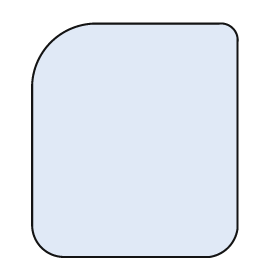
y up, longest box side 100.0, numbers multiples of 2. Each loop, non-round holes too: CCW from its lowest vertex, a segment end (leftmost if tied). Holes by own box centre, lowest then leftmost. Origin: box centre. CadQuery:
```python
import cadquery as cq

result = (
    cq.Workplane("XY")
    .moveTo(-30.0, -50.0)
    .lineTo(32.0, -50.0)
    .threePointArc((40.0, -46.0), (44.0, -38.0))
    .lineTo(44.0, 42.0)
    .threePointArc((42.0, 48.0), (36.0, 50.0))
    .lineTo(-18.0, 50.0)
    .threePointArc((-36.0, 42.0), (-44.0, 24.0))
    .lineTo(-44.0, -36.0)
    .threePointArc((-40.0, -46.0), (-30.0, -50.0))
    .close()
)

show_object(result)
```